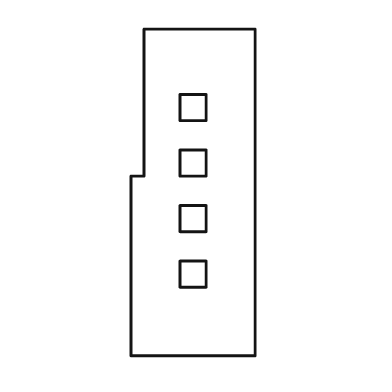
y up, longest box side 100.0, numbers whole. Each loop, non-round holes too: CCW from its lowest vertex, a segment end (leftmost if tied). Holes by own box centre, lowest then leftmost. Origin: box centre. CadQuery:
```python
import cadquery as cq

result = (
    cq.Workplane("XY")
    .moveTo(-19.0, -50.0)
    .lineTo(19.0, -50.0)
    .lineTo(19.0, 50.0)
    .lineTo(-15.0, 50.0)
    .lineTo(-15.0, 5.0)
    .lineTo(-19.0, 5.0)
    .close()
    .moveTo(-4.0, -29.0)
    .lineTo(4.0, -29.0)
    .lineTo(4.0, -21.0)
    .lineTo(-4.0, -21.0)
    .close()
    .moveTo(-4.0, -12.0)
    .lineTo(4.0, -12.0)
    .lineTo(4.0, -4.0)
    .lineTo(-4.0, -4.0)
    .close()
    .moveTo(-4.0, 5.0)
    .lineTo(4.0, 5.0)
    .lineTo(4.0, 13.0)
    .lineTo(-4.0, 13.0)
    .close()
    .moveTo(-4.0, 22.0)
    .lineTo(4.0, 22.0)
    .lineTo(4.0, 30.0)
    .lineTo(-4.0, 30.0)
    .close()
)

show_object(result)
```